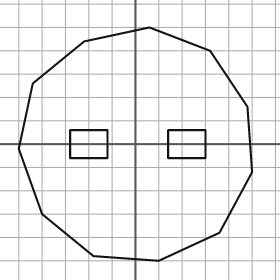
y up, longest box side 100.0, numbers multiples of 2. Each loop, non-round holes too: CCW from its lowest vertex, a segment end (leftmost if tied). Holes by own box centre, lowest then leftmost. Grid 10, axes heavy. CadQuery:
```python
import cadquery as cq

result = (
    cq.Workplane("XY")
    .moveTo(10.0, -50.0)
    .lineTo(36.0, -38.0)
    .lineTo(50.0, -12.0)
    .lineTo(48.0, 16.0)
    .lineTo(32.0, 40.0)
    .lineTo(6.0, 50.0)
    .lineTo(-22.0, 44.0)
    .lineTo(-44.0, 26.0)
    .lineTo(-50.0, -2.0)
    .lineTo(-40.0, -30.0)
    .lineTo(-18.0, -48.0)
    .close()
    .moveTo(-28.0, -6.0)
    .lineTo(-12.0, -6.0)
    .lineTo(-12.0, 6.0)
    .lineTo(-28.0, 6.0)
    .close()
    .moveTo(14.0, -6.0)
    .lineTo(30.0, -6.0)
    .lineTo(30.0, 6.0)
    .lineTo(14.0, 6.0)
    .close()
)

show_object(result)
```